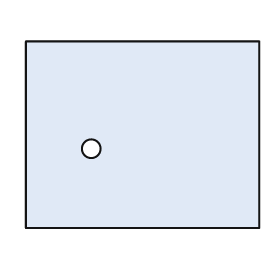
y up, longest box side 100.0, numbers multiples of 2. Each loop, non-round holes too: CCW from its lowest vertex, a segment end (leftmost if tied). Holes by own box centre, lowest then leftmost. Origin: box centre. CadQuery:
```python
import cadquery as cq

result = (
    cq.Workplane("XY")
    .moveTo(-50.0, -40.0)
    .lineTo(50.0, -40.0)
    .lineTo(50.0, 40.0)
    .lineTo(-50.0, 40.0)
    .close()
    .moveTo(-22.0, -6.0)
    .circle(4.0)
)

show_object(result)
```